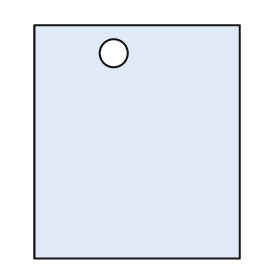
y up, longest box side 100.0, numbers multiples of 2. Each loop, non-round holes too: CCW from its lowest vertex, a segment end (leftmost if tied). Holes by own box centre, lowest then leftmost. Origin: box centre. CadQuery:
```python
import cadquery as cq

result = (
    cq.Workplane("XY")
    .moveTo(-44.0, -50.0)
    .lineTo(44.0, -50.0)
    .lineTo(44.0, 50.0)
    .lineTo(-44.0, 50.0)
    .close()
    .moveTo(-10.0, 38.0)
    .circle(6.0)
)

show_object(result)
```